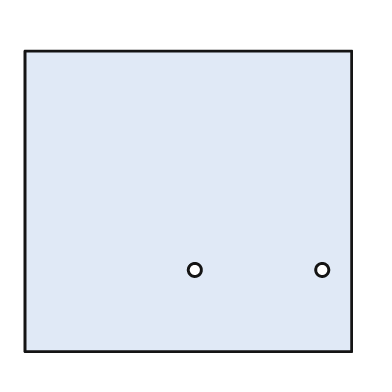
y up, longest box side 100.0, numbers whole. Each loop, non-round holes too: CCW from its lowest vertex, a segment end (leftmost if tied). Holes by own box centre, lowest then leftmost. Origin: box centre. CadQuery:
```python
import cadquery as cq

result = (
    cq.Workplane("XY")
    .moveTo(-50.0, -46.0)
    .lineTo(50.0, -46.0)
    .lineTo(50.0, 46.0)
    .lineTo(-50.0, 46.0)
    .close()
    .moveTo(2.0, -21.0)
    .circle(2.0)
    .moveTo(41.0, -21.0)
    .circle(2.0)
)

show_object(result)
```